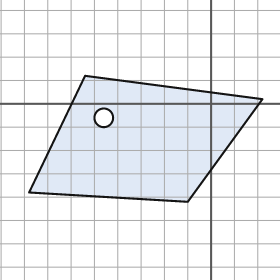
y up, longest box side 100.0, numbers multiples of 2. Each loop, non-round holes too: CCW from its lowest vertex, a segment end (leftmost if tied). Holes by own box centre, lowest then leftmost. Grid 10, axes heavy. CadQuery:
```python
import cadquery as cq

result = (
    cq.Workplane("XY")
    .moveTo(-10.0, -42.0)
    .lineTo(22.0, 2.0)
    .lineTo(-54.0, 12.0)
    .lineTo(-78.0, -38.0)
    .close()
    .moveTo(-46.0, -6.0)
    .circle(4.0)
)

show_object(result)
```